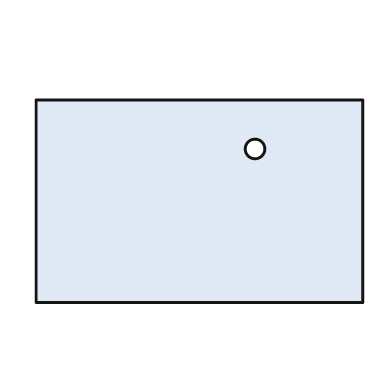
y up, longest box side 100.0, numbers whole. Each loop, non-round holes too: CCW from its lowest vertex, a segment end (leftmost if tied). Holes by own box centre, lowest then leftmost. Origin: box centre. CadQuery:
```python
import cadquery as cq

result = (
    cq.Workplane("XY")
    .moveTo(-50.0, -31.0)
    .lineTo(50.0, -31.0)
    .lineTo(50.0, 31.0)
    .lineTo(-50.0, 31.0)
    .close()
    .moveTo(17.0, 16.0)
    .circle(3.0)
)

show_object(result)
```